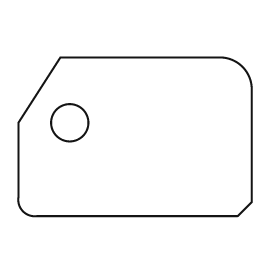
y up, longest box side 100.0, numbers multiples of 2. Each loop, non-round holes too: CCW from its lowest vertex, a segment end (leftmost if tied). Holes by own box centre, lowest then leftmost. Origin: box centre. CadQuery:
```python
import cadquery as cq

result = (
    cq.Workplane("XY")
    .moveTo(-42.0, -34.0)
    .lineTo(44.0, -34.0)
    .lineTo(50.0, -28.0)
    .lineTo(50.0, 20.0)
    .threePointArc((46.0, 30.0), (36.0, 34.0))
    .lineTo(-32.0, 34.0)
    .lineTo(-50.0, 6.0)
    .lineTo(-50.0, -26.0)
    .threePointArc((-48.0, -32.0), (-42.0, -34.0))
    .close()
    .moveTo(-28.0, 6.0)
    .circle(8.0)
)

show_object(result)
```